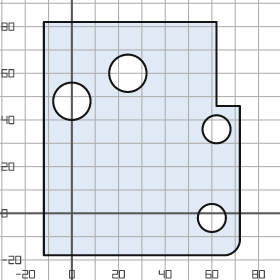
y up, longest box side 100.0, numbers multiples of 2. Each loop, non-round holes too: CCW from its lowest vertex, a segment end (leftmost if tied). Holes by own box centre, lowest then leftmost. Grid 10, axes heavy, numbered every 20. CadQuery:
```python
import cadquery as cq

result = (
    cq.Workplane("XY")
    .moveTo(-12.0, -18.0)
    .lineTo(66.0, -18.0)
    .threePointArc((70.0, -16.0), (72.0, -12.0))
    .lineTo(72.0, 46.0)
    .lineTo(62.0, 46.0)
    .lineTo(62.0, 82.0)
    .lineTo(-12.0, 82.0)
    .close()
    .moveTo(60.0, -2.0)
    .circle(6.0)
    .moveTo(62.0, 36.0)
    .circle(6.0)
    .moveTo(0.0, 48.0)
    .circle(8.0)
    .moveTo(24.0, 60.0)
    .circle(8.0)
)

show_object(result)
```